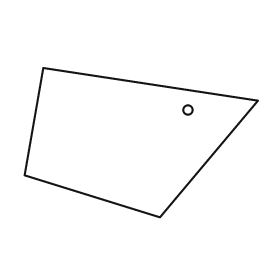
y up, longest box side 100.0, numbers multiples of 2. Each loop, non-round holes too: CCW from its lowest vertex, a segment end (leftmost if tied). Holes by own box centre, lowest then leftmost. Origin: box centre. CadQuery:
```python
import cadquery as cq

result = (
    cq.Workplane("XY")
    .moveTo(8.0, -32.0)
    .lineTo(50.0, 18.0)
    .lineTo(-42.0, 32.0)
    .lineTo(-50.0, -14.0)
    .close()
    .moveTo(20.0, 14.0)
    .circle(2.0)
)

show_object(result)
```